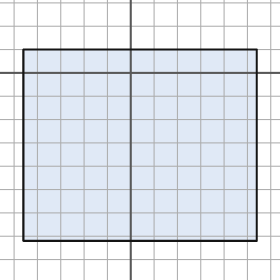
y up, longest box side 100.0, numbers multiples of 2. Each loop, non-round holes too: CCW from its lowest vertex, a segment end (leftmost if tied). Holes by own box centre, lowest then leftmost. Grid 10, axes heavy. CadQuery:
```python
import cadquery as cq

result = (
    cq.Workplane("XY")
    .moveTo(-46.0, -72.0)
    .lineTo(54.0, -72.0)
    .lineTo(54.0, 10.0)
    .lineTo(-46.0, 10.0)
    .close()
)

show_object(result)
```